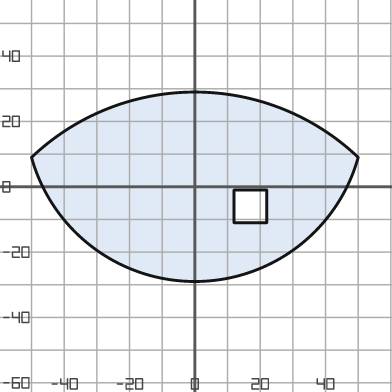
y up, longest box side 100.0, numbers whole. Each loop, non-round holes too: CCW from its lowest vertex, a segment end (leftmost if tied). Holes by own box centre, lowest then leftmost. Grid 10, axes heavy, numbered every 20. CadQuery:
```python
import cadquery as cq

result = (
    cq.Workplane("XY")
    .moveTo(-50.0, 9.0)
    .threePointArc((0.0, -29.0), (50.0, 9.0))
    .threePointArc((0.0, 29.0), (-50.0, 9.0))
    .close()
    .moveTo(12.0, -11.0)
    .lineTo(22.0, -11.0)
    .lineTo(22.0, -1.0)
    .lineTo(12.0, -1.0)
    .close()
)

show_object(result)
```